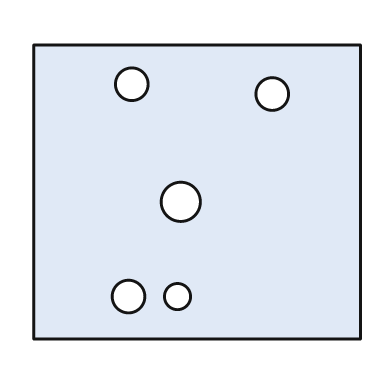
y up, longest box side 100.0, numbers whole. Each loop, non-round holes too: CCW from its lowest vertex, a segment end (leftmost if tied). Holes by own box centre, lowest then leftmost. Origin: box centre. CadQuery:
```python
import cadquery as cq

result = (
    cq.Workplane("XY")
    .moveTo(-50.0, -45.0)
    .lineTo(50.0, -45.0)
    .lineTo(50.0, 45.0)
    .lineTo(-50.0, 45.0)
    .close()
    .moveTo(-21.0, -32.0)
    .circle(5.0)
    .moveTo(-6.0, -32.0)
    .circle(4.0)
    .moveTo(-5.0, -3.0)
    .circle(6.0)
    .moveTo(23.0, 30.0)
    .circle(5.0)
    .moveTo(-20.0, 33.0)
    .circle(5.0)
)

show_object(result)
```